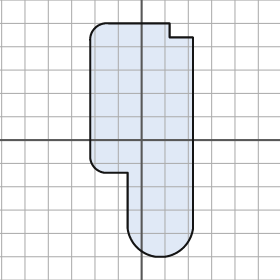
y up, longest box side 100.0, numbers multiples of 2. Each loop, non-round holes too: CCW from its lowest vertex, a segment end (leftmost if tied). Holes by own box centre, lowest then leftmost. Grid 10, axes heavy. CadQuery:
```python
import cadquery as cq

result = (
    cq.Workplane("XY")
    .moveTo(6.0, -50.0)
    .lineTo(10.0, -50.0)
    .threePointArc((18.0, -46.0), (22.0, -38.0))
    .lineTo(22.0, 44.0)
    .lineTo(12.0, 44.0)
    .lineTo(12.0, 50.0)
    .lineTo(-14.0, 50.0)
    .threePointArc((-20.0, 48.0), (-22.0, 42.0))
    .lineTo(-22.0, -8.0)
    .threePointArc((-20.0, -12.0), (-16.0, -14.0))
    .lineTo(-6.0, -14.0)
    .lineTo(-6.0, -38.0)
    .threePointArc((-2.0, -46.0), (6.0, -50.0))
    .close()
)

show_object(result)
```